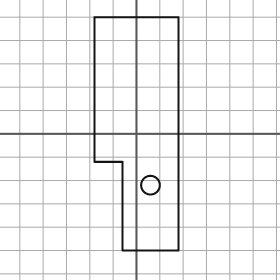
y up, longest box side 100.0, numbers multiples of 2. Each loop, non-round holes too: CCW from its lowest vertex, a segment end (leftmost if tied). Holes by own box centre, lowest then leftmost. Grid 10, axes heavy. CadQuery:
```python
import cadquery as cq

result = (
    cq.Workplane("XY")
    .moveTo(-6.0, -50.0)
    .lineTo(18.0, -50.0)
    .lineTo(18.0, 50.0)
    .lineTo(-18.0, 50.0)
    .lineTo(-18.0, -12.0)
    .lineTo(-6.0, -12.0)
    .close()
    .moveTo(6.0, -22.0)
    .circle(4.0)
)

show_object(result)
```